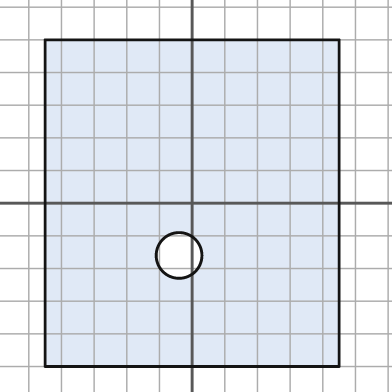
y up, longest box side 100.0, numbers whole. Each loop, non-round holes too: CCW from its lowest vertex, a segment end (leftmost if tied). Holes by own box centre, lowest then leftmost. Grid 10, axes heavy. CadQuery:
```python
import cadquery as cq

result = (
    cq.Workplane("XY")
    .moveTo(-45.0, -50.0)
    .lineTo(45.0, -50.0)
    .lineTo(45.0, 50.0)
    .lineTo(-45.0, 50.0)
    .close()
    .moveTo(-4.0, -16.0)
    .circle(7.0)
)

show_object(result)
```